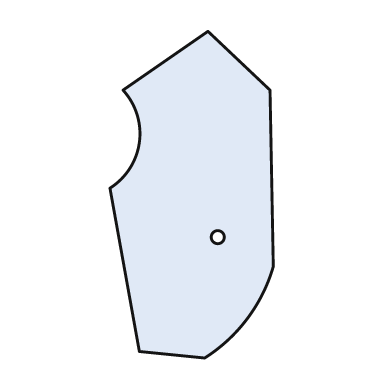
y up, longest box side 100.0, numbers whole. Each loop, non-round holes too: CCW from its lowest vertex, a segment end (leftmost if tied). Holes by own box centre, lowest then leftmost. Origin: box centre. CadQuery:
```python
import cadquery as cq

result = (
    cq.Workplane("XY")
    .moveTo(4.0, -50.0)
    .threePointArc((17.0, -38.0), (25.0, -22.0))
    .lineTo(24.0, 32.0)
    .lineTo(5.0, 50.0)
    .lineTo(-21.0, 32.0)
    .threePointArc((-16.0, 16.0), (-25.0, 2.0))
    .lineTo(-16.0, -48.0)
    .close()
    .moveTo(8.0, -13.0)
    .circle(2.0)
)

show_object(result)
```